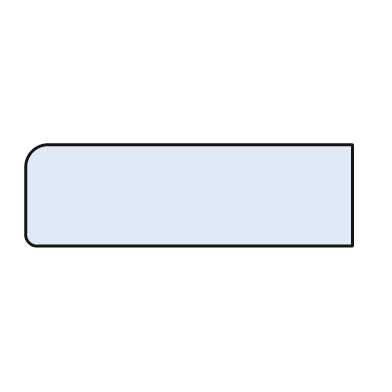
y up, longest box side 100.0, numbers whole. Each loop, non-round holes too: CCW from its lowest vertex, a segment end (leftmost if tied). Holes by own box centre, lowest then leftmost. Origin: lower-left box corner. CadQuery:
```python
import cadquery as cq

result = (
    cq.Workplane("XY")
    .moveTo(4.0, 0.0)
    .lineTo(100.0, 0.0)
    .lineTo(100.0, 31.0)
    .lineTo(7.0, 31.0)
    .threePointArc((2.0, 29.0), (0.0, 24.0))
    .lineTo(0.0, 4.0)
    .threePointArc((1.0, 1.0), (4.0, 0.0))
    .close()
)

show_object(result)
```